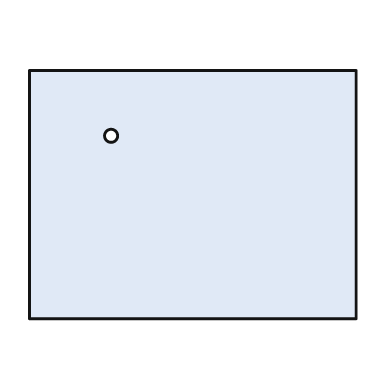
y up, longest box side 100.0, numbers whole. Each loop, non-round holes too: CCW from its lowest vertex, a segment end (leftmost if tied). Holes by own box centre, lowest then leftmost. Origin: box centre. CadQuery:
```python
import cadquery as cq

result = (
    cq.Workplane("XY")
    .moveTo(-50.0, -38.0)
    .lineTo(50.0, -38.0)
    .lineTo(50.0, 38.0)
    .lineTo(-50.0, 38.0)
    .close()
    .moveTo(-25.0, 18.0)
    .circle(2.0)
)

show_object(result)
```